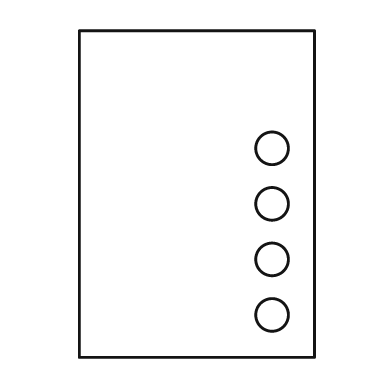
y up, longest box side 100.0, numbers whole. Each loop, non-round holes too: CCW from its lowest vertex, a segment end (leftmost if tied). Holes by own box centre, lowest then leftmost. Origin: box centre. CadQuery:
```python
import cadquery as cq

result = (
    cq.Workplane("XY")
    .moveTo(-36.0, -50.0)
    .lineTo(36.0, -50.0)
    .lineTo(36.0, 50.0)
    .lineTo(-36.0, 50.0)
    .close()
    .moveTo(23.0, -37.0)
    .circle(5.0)
    .moveTo(23.0, -20.0)
    .circle(5.0)
    .moveTo(23.0, -3.0)
    .circle(5.0)
    .moveTo(23.0, 14.0)
    .circle(5.0)
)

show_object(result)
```